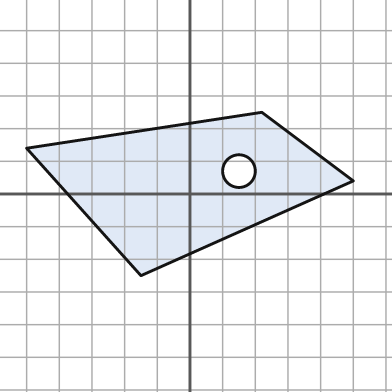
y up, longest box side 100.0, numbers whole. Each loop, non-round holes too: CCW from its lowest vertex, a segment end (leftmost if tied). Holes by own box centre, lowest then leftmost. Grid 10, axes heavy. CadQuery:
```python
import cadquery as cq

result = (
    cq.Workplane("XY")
    .moveTo(-15.0, -25.0)
    .lineTo(50.0, 4.0)
    .lineTo(22.0, 25.0)
    .lineTo(-50.0, 14.0)
    .close()
    .moveTo(15.0, 7.0)
    .circle(5.0)
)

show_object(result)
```